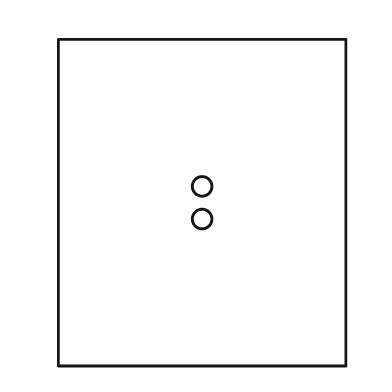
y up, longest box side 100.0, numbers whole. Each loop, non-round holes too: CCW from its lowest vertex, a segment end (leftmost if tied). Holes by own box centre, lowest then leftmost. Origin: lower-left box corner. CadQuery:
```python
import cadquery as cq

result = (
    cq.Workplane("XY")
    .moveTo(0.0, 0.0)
    .lineTo(88.0, 0.0)
    .lineTo(88.0, 100.0)
    .lineTo(0.0, 100.0)
    .close()
    .moveTo(44.0, 45.0)
    .circle(3.0)
    .moveTo(44.0, 55.0)
    .circle(3.0)
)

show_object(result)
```